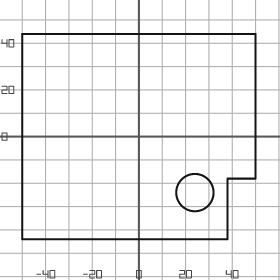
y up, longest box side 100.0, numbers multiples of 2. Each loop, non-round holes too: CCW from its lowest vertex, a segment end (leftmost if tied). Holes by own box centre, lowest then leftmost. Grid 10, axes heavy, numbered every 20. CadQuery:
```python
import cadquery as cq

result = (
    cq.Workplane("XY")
    .moveTo(-50.0, -44.0)
    .lineTo(38.0, -44.0)
    .lineTo(38.0, -18.0)
    .lineTo(50.0, -18.0)
    .lineTo(50.0, 44.0)
    .lineTo(-50.0, 44.0)
    .close()
    .moveTo(24.0, -24.0)
    .circle(8.0)
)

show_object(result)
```